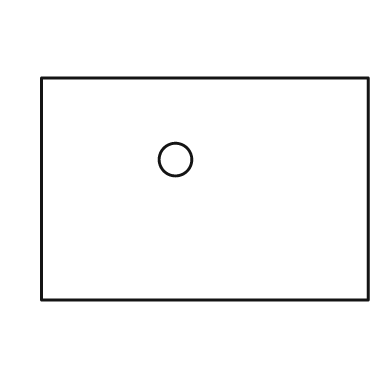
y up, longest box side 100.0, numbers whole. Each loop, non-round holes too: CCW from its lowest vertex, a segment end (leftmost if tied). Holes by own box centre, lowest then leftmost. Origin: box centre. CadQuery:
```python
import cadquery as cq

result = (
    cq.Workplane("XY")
    .moveTo(-50.0, -34.0)
    .lineTo(50.0, -34.0)
    .lineTo(50.0, 34.0)
    .lineTo(-50.0, 34.0)
    .close()
    .moveTo(-9.0, 9.0)
    .circle(5.0)
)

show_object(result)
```